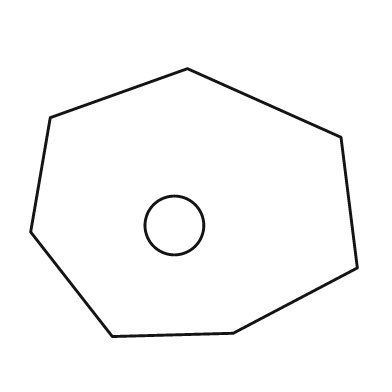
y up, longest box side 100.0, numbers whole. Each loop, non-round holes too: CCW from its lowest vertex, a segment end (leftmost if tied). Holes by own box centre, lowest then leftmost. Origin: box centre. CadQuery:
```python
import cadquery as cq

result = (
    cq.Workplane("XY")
    .moveTo(-25.0, -41.0)
    .lineTo(12.0, -40.0)
    .lineTo(50.0, -20.0)
    .lineTo(45.0, 20.0)
    .lineTo(-2.0, 41.0)
    .lineTo(-44.0, 26.0)
    .lineTo(-50.0, -9.0)
    .close()
    .moveTo(-6.0, -7.0)
    .circle(9.0)
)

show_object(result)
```